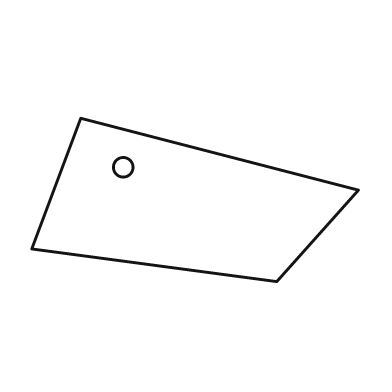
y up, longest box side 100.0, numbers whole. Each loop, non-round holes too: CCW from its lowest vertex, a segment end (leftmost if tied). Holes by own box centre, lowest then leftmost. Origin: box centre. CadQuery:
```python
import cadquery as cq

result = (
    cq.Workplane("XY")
    .moveTo(25.0, -25.0)
    .lineTo(50.0, 3.0)
    .lineTo(-35.0, 25.0)
    .lineTo(-50.0, -15.0)
    .close()
    .moveTo(-22.0, 10.0)
    .circle(3.0)
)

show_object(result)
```